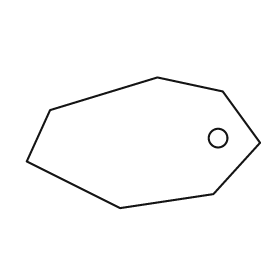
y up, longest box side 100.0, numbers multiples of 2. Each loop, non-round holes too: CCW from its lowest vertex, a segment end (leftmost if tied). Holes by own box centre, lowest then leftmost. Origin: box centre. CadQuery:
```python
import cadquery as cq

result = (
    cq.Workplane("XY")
    .moveTo(-10.0, -28.0)
    .lineTo(30.0, -22.0)
    .lineTo(50.0, 0.0)
    .lineTo(34.0, 22.0)
    .lineTo(6.0, 28.0)
    .lineTo(-40.0, 14.0)
    .lineTo(-50.0, -8.0)
    .close()
    .moveTo(32.0, 2.0)
    .circle(4.0)
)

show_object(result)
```